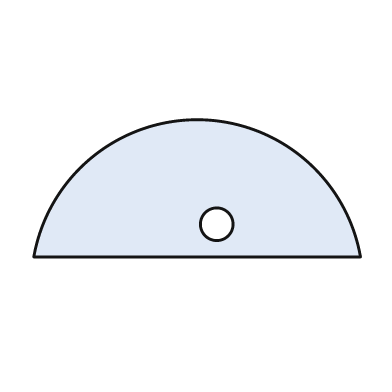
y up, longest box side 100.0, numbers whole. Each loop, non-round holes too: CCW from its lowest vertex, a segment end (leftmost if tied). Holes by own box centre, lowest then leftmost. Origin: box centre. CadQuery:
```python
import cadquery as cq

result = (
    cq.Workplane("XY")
    .moveTo(-50.0, -21.0)
    .lineTo(50.0, -21.0)
    .threePointArc((0.0, 21.0), (-50.0, -21.0))
    .close()
    .moveTo(6.0, -11.0)
    .circle(5.0)
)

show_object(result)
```